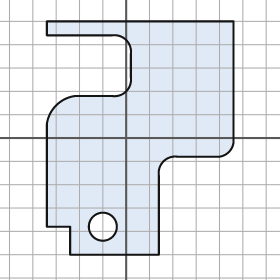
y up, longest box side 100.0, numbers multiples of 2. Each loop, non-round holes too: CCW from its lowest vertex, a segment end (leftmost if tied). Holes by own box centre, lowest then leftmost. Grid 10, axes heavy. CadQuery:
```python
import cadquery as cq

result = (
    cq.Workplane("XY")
    .moveTo(-24.0, -50.0)
    .lineTo(14.0, -50.0)
    .lineTo(14.0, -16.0)
    .threePointArc((16.0, -10.0), (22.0, -8.0))
    .lineTo(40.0, -8.0)
    .threePointArc((44.0, -6.0), (46.0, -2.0))
    .lineTo(46.0, 50.0)
    .lineTo(-34.0, 50.0)
    .lineTo(-34.0, 44.0)
    .lineTo(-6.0, 44.0)
    .threePointArc((0.0, 42.0), (2.0, 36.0))
    .lineTo(2.0, 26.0)
    .threePointArc((0.0, 20.0), (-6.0, 18.0))
    .lineTo(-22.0, 18.0)
    .threePointArc((-30.0, 14.0), (-34.0, 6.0))
    .lineTo(-34.0, -38.0)
    .lineTo(-24.0, -38.0)
    .close()
    .moveTo(-10.0, -38.0)
    .circle(6.0)
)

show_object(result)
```